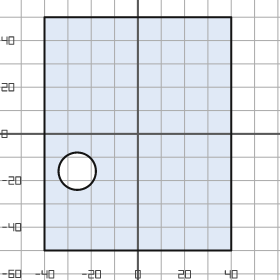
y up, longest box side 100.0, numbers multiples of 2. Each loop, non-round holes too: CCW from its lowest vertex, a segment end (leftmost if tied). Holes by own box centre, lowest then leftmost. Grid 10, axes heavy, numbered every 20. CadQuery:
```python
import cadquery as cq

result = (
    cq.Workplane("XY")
    .moveTo(-40.0, -50.0)
    .lineTo(40.0, -50.0)
    .lineTo(40.0, 50.0)
    .lineTo(-40.0, 50.0)
    .close()
    .moveTo(-26.0, -16.0)
    .circle(8.0)
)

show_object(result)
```